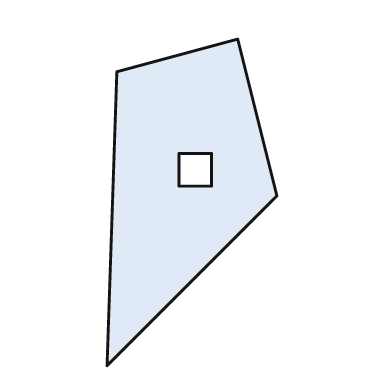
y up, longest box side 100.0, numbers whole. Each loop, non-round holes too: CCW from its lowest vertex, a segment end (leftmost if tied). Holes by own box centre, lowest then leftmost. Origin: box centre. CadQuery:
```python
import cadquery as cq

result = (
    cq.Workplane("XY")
    .moveTo(-26.0, -50.0)
    .lineTo(26.0, 2.0)
    .lineTo(14.0, 50.0)
    .lineTo(-23.0, 40.0)
    .close()
    .moveTo(-4.0, 5.0)
    .lineTo(6.0, 5.0)
    .lineTo(6.0, 15.0)
    .lineTo(-4.0, 15.0)
    .close()
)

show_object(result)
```